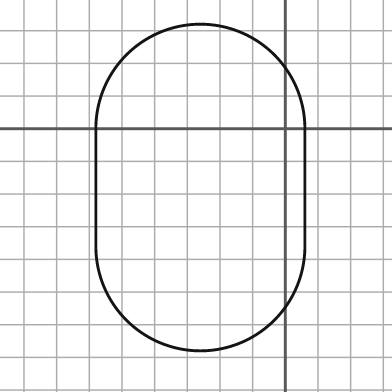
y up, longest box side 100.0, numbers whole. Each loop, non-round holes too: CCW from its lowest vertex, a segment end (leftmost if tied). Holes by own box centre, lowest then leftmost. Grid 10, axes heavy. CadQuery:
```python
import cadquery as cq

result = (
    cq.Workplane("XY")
    .moveTo(-58.0, -36.0)
    .threePointArc((-26.0, -68.0), (6.0, -36.0))
    .lineTo(6.0, 0.0)
    .threePointArc((-26.0, 32.0), (-58.0, 0.0))
    .close()
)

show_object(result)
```